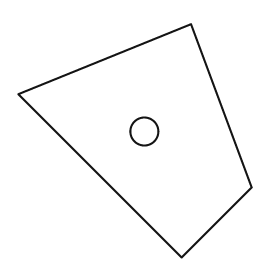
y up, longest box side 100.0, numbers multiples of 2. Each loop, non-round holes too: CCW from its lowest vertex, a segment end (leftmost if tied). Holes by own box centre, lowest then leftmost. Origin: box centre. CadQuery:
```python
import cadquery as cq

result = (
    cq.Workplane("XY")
    .moveTo(20.0, -50.0)
    .lineTo(50.0, -20.0)
    .lineTo(24.0, 50.0)
    .lineTo(-50.0, 20.0)
    .close()
    .moveTo(4.0, 4.0)
    .circle(6.0)
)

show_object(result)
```